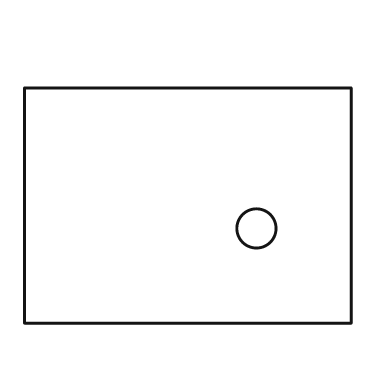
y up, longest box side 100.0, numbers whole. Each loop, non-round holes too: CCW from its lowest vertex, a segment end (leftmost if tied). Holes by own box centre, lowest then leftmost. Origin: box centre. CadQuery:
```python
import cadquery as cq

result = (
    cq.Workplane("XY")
    .moveTo(-50.0, -36.0)
    .lineTo(50.0, -36.0)
    .lineTo(50.0, 36.0)
    .lineTo(-50.0, 36.0)
    .close()
    .moveTo(21.0, -7.0)
    .circle(6.0)
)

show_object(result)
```